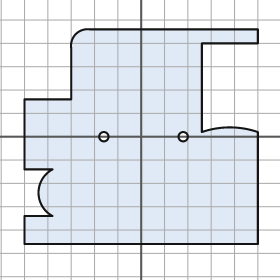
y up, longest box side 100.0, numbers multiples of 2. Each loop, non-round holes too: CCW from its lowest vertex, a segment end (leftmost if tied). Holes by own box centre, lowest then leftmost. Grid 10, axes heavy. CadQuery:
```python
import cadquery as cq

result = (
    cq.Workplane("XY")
    .moveTo(-50.0, -46.0)
    .lineTo(50.0, -46.0)
    .lineTo(50.0, 2.0)
    .threePointArc((38.0, 4.0), (26.0, 2.0))
    .lineTo(26.0, 40.0)
    .lineTo(50.0, 40.0)
    .lineTo(50.0, 46.0)
    .lineTo(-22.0, 46.0)
    .threePointArc((-28.0, 44.0), (-30.0, 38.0))
    .lineTo(-30.0, 16.0)
    .lineTo(-50.0, 16.0)
    .lineTo(-50.0, -14.0)
    .lineTo(-38.0, -14.0)
    .threePointArc((-44.0, -24.0), (-38.0, -34.0))
    .lineTo(-50.0, -34.0)
    .close()
    .moveTo(-16.0, 0.0)
    .circle(2.0)
    .moveTo(18.0, 0.0)
    .circle(2.0)
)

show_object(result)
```